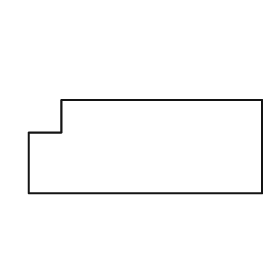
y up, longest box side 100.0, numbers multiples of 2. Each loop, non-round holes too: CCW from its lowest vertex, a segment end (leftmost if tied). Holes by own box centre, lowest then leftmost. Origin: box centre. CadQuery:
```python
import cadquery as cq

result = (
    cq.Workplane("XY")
    .moveTo(-50.0, -20.0)
    .lineTo(50.0, -20.0)
    .lineTo(50.0, 20.0)
    .lineTo(-36.0, 20.0)
    .lineTo(-36.0, 6.0)
    .lineTo(-50.0, 6.0)
    .close()
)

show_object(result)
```